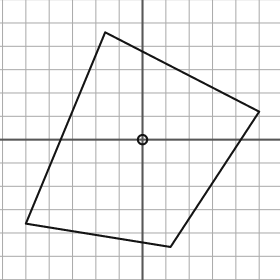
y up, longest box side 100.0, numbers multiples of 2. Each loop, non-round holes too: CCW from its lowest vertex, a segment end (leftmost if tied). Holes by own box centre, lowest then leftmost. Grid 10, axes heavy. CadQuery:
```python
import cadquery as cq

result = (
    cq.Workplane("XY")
    .moveTo(12.0, -46.0)
    .lineTo(50.0, 12.0)
    .lineTo(-16.0, 46.0)
    .lineTo(-50.0, -36.0)
    .close()
    .moveTo(0.0, 0.0)
    .circle(2.0)
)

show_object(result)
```